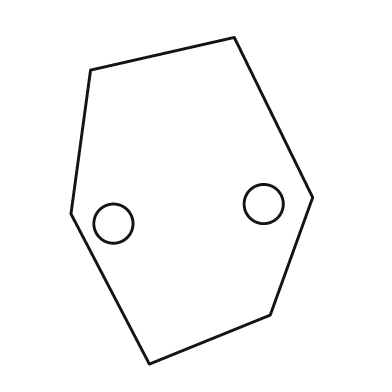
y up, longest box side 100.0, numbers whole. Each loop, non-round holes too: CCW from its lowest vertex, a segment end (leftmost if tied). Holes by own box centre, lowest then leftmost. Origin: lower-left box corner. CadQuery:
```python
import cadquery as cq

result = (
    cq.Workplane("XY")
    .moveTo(24.0, 0.0)
    .lineTo(61.0, 15.0)
    .lineTo(74.0, 51.0)
    .lineTo(50.0, 100.0)
    .lineTo(6.0, 90.0)
    .lineTo(0.0, 46.0)
    .close()
    .moveTo(13.0, 43.0)
    .circle(6.0)
    .moveTo(59.0, 49.0)
    .circle(6.0)
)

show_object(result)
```